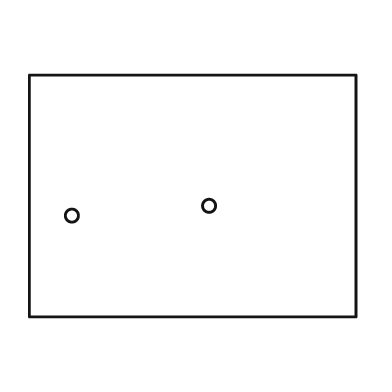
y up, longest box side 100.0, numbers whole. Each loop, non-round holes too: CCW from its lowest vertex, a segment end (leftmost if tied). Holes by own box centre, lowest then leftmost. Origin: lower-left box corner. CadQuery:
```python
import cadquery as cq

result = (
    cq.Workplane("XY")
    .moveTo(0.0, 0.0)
    .lineTo(100.0, 0.0)
    .lineTo(100.0, 74.0)
    .lineTo(0.0, 74.0)
    .close()
    .moveTo(13.0, 31.0)
    .circle(2.0)
    .moveTo(55.0, 34.0)
    .circle(2.0)
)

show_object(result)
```